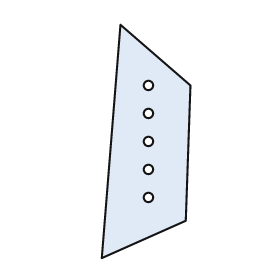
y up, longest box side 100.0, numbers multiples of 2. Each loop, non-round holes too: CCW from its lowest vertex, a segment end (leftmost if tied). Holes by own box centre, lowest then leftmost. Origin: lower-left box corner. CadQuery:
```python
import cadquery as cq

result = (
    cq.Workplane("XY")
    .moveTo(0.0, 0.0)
    .lineTo(36.0, 16.0)
    .lineTo(38.0, 74.0)
    .lineTo(8.0, 100.0)
    .close()
    .moveTo(20.0, 26.0)
    .circle(2.0)
    .moveTo(20.0, 38.0)
    .circle(2.0)
    .moveTo(20.0, 50.0)
    .circle(2.0)
    .moveTo(20.0, 62.0)
    .circle(2.0)
    .moveTo(20.0, 74.0)
    .circle(2.0)
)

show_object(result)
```